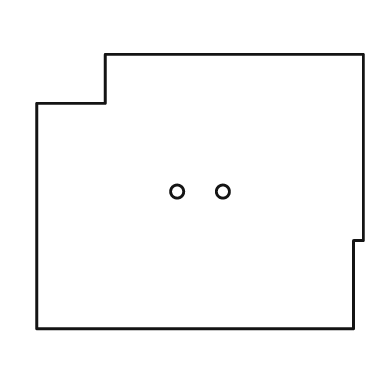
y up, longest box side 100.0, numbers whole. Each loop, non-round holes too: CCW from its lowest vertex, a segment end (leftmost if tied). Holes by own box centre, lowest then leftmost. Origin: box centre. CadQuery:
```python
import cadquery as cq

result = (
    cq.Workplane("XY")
    .moveTo(-50.0, -42.0)
    .lineTo(47.0, -42.0)
    .lineTo(47.0, -15.0)
    .lineTo(50.0, -15.0)
    .lineTo(50.0, 42.0)
    .lineTo(-29.0, 42.0)
    .lineTo(-29.0, 27.0)
    .lineTo(-50.0, 27.0)
    .close()
    .moveTo(-7.0, 0.0)
    .circle(2.0)
    .moveTo(7.0, 0.0)
    .circle(2.0)
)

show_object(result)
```